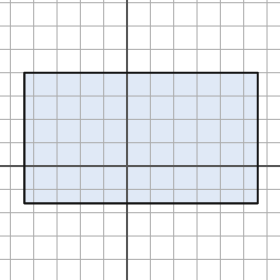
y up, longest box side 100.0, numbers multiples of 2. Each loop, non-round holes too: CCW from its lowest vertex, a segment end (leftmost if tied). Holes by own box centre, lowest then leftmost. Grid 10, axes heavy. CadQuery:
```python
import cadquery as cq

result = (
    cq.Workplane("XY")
    .moveTo(-44.0, -16.0)
    .lineTo(56.0, -16.0)
    .lineTo(56.0, 40.0)
    .lineTo(-44.0, 40.0)
    .close()
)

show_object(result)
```